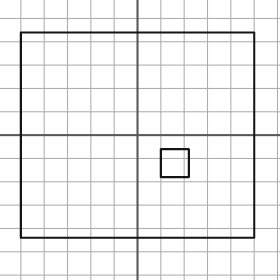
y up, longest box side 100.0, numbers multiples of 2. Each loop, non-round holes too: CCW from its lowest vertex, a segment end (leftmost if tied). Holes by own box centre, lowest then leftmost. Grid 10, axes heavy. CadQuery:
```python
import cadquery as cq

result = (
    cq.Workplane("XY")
    .moveTo(-50.0, -44.0)
    .lineTo(50.0, -44.0)
    .lineTo(50.0, 44.0)
    .lineTo(-50.0, 44.0)
    .close()
    .moveTo(10.0, -18.0)
    .lineTo(22.0, -18.0)
    .lineTo(22.0, -6.0)
    .lineTo(10.0, -6.0)
    .close()
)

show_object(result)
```